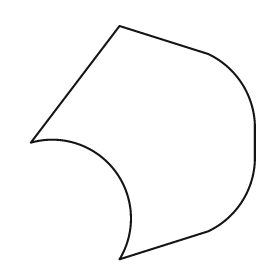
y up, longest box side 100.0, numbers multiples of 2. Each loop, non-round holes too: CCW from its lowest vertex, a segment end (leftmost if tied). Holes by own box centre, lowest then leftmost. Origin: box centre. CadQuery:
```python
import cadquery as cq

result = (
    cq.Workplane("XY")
    .moveTo(-10.0, -50.0)
    .lineTo(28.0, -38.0)
    .threePointArc((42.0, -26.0), (48.0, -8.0))
    .lineTo(48.0, 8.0)
    .threePointArc((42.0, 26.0), (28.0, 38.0))
    .lineTo(-10.0, 50.0)
    .lineTo(-48.0, 0.0)
    .threePointArc((-12.0, -12.0), (-10.0, -50.0))
    .close()
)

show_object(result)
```